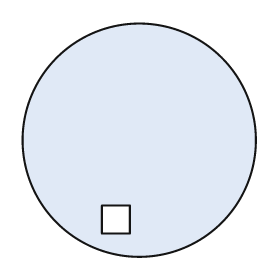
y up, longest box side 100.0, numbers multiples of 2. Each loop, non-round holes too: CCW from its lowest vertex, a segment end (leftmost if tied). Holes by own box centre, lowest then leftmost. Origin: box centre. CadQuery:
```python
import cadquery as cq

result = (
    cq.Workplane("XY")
    .moveTo(0.0, 0.0)
    .circle(50.0)
    .moveTo(-16.0, -40.0)
    .lineTo(-4.0, -40.0)
    .lineTo(-4.0, -28.0)
    .lineTo(-16.0, -28.0)
    .close()
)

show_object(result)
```